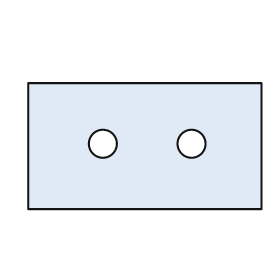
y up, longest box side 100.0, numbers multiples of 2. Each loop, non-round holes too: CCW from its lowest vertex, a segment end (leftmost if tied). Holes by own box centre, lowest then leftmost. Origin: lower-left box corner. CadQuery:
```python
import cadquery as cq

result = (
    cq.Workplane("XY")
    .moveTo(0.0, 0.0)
    .lineTo(100.0, 0.0)
    .lineTo(100.0, 54.0)
    .lineTo(0.0, 54.0)
    .close()
    .moveTo(32.0, 28.0)
    .circle(6.0)
    .moveTo(70.0, 28.0)
    .circle(6.0)
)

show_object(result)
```